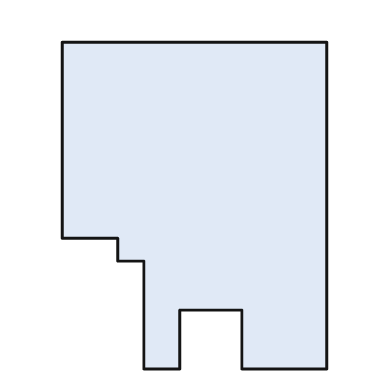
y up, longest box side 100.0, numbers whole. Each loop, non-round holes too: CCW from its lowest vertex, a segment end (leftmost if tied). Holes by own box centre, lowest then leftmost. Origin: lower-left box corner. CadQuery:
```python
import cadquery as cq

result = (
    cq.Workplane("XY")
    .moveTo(25.0, 0.0)
    .lineTo(36.0, 0.0)
    .lineTo(36.0, 18.0)
    .lineTo(55.0, 18.0)
    .lineTo(55.0, 0.0)
    .lineTo(81.0, 0.0)
    .lineTo(81.0, 100.0)
    .lineTo(0.0, 100.0)
    .lineTo(0.0, 40.0)
    .lineTo(17.0, 40.0)
    .lineTo(17.0, 33.0)
    .lineTo(25.0, 33.0)
    .close()
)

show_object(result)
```